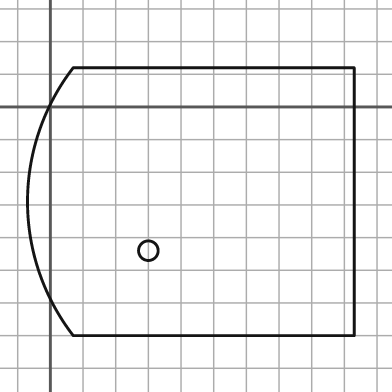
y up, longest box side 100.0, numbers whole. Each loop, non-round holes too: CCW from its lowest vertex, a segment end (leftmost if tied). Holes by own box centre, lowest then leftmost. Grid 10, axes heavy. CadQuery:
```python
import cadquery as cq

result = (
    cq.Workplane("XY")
    .moveTo(7.0, -70.0)
    .lineTo(93.0, -70.0)
    .lineTo(93.0, 12.0)
    .lineTo(7.0, 12.0)
    .threePointArc((-7.0, -29.0), (7.0, -70.0))
    .close()
    .moveTo(30.0, -44.0)
    .circle(3.0)
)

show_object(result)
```